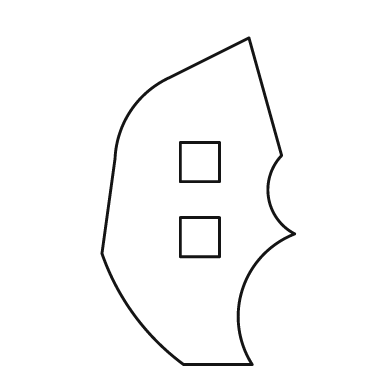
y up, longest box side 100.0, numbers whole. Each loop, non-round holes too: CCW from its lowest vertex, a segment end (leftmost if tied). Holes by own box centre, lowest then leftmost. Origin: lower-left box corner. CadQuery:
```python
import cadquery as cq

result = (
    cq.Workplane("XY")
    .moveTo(25.0, 0.0)
    .lineTo(46.0, 0.0)
    .threePointArc((43.0, 23.0), (59.0, 40.0))
    .threePointArc((51.0, 51.0), (55.0, 64.0))
    .lineTo(45.0, 100.0)
    .lineTo(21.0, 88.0)
    .threePointArc((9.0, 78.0), (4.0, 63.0))
    .lineTo(0.0, 34.0)
    .threePointArc((10.0, 15.0), (25.0, 0.0))
    .close()
    .moveTo(24.0, 33.0)
    .lineTo(36.0, 33.0)
    .lineTo(36.0, 45.0)
    .lineTo(24.0, 45.0)
    .close()
    .moveTo(24.0, 56.0)
    .lineTo(36.0, 56.0)
    .lineTo(36.0, 68.0)
    .lineTo(24.0, 68.0)
    .close()
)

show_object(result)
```